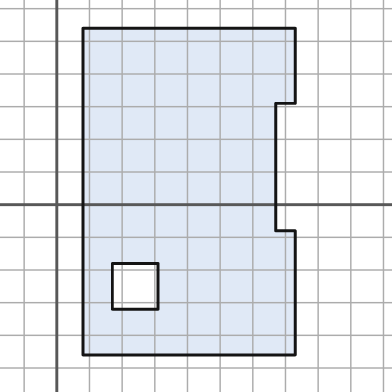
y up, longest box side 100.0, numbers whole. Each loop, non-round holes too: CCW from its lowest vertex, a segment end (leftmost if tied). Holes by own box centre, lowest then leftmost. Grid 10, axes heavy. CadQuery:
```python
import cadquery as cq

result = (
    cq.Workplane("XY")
    .moveTo(8.0, -46.0)
    .lineTo(73.0, -46.0)
    .lineTo(73.0, -8.0)
    .lineTo(67.0, -8.0)
    .lineTo(67.0, 31.0)
    .lineTo(73.0, 31.0)
    .lineTo(73.0, 54.0)
    .lineTo(8.0, 54.0)
    .close()
    .moveTo(17.0, -32.0)
    .lineTo(31.0, -32.0)
    .lineTo(31.0, -18.0)
    .lineTo(17.0, -18.0)
    .close()
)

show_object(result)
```